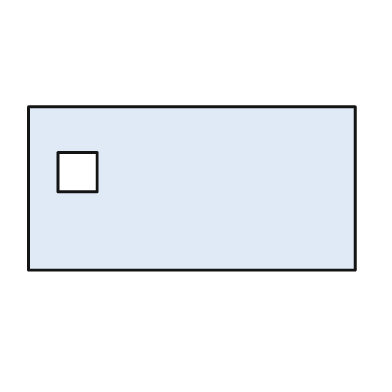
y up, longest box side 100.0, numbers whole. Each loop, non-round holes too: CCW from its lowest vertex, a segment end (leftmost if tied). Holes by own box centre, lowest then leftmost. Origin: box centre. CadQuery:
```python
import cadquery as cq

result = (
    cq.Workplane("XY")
    .moveTo(-50.0, -25.0)
    .lineTo(50.0, -25.0)
    .lineTo(50.0, 25.0)
    .lineTo(-50.0, 25.0)
    .close()
    .moveTo(-41.0, -1.0)
    .lineTo(-29.0, -1.0)
    .lineTo(-29.0, 11.0)
    .lineTo(-41.0, 11.0)
    .close()
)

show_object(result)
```